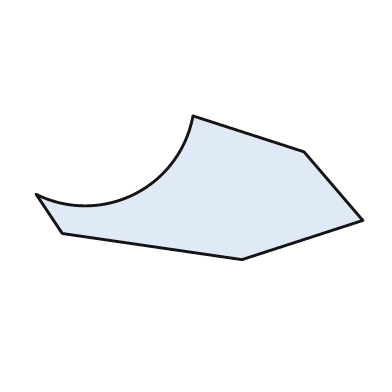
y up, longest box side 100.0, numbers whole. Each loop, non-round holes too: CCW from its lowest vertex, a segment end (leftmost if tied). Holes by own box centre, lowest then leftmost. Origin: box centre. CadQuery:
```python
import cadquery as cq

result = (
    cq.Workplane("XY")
    .moveTo(13.0, -22.0)
    .lineTo(50.0, -10.0)
    .lineTo(32.0, 11.0)
    .lineTo(-2.0, 22.0)
    .threePointArc((-20.0, -2.0), (-50.0, -2.0))
    .lineTo(-42.0, -14.0)
    .close()
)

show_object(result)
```